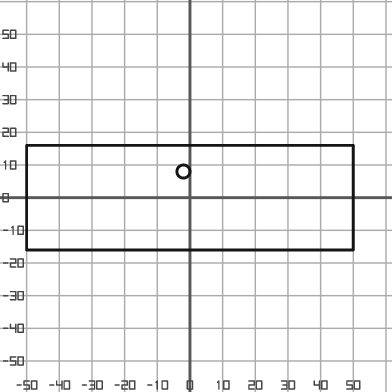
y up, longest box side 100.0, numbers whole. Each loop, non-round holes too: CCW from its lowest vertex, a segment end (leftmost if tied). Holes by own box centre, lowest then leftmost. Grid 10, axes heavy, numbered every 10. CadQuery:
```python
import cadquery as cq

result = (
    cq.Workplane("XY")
    .moveTo(-50.0, -16.0)
    .lineTo(50.0, -16.0)
    .lineTo(50.0, 16.0)
    .lineTo(-50.0, 16.0)
    .close()
    .moveTo(-2.0, 8.0)
    .circle(2.0)
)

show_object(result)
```